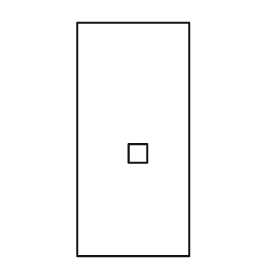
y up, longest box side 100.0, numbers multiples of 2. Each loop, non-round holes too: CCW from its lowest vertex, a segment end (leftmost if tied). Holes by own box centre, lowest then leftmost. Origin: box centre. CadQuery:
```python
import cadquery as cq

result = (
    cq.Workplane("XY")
    .moveTo(-24.0, -50.0)
    .lineTo(24.0, -50.0)
    .lineTo(24.0, 50.0)
    .lineTo(-24.0, 50.0)
    .close()
    .moveTo(-2.0, -10.0)
    .lineTo(6.0, -10.0)
    .lineTo(6.0, -2.0)
    .lineTo(-2.0, -2.0)
    .close()
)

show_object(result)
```